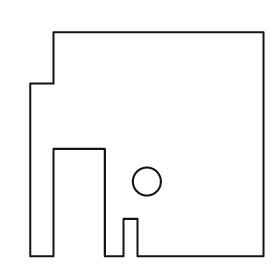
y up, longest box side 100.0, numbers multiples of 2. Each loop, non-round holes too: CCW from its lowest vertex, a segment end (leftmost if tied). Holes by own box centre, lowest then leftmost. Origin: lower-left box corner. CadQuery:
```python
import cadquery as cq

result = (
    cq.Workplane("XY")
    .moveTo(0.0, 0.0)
    .lineTo(10.0, 0.0)
    .lineTo(10.0, 46.0)
    .lineTo(32.0, 46.0)
    .lineTo(32.0, 0.0)
    .lineTo(40.0, 0.0)
    .lineTo(40.0, 16.0)
    .lineTo(46.0, 16.0)
    .lineTo(46.0, 0.0)
    .lineTo(100.0, 0.0)
    .lineTo(100.0, 96.0)
    .lineTo(10.0, 96.0)
    .lineTo(10.0, 74.0)
    .lineTo(0.0, 74.0)
    .close()
    .moveTo(50.0, 32.0)
    .circle(6.0)
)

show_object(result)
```